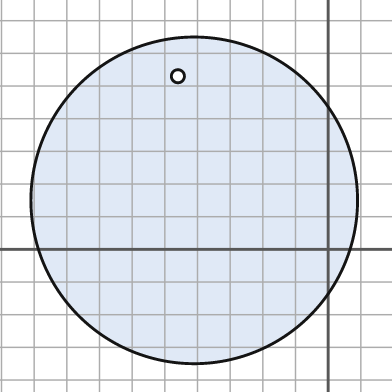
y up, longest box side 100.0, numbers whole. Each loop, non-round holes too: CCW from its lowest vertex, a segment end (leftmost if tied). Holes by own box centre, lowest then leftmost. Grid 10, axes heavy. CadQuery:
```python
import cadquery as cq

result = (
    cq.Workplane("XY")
    .moveTo(-41.0, 15.0)
    .circle(50.0)
    .moveTo(-46.0, 53.0)
    .circle(2.0)
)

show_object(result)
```